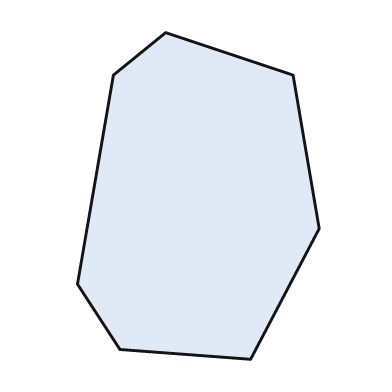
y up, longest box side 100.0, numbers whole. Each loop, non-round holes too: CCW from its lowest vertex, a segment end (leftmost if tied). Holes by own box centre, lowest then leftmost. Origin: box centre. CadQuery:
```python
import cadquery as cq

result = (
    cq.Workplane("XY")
    .moveTo(16.0, -50.0)
    .lineTo(37.0, -10.0)
    .lineTo(29.0, 37.0)
    .lineTo(-10.0, 50.0)
    .lineTo(-26.0, 37.0)
    .lineTo(-37.0, -27.0)
    .lineTo(-24.0, -47.0)
    .close()
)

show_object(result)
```